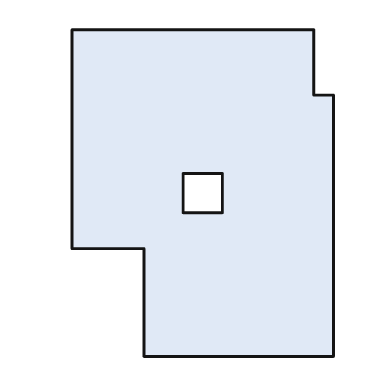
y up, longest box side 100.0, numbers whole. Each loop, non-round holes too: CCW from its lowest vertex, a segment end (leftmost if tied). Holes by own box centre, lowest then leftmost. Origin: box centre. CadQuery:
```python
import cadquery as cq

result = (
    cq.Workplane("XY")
    .moveTo(-18.0, -50.0)
    .lineTo(40.0, -50.0)
    .lineTo(40.0, 30.0)
    .lineTo(34.0, 30.0)
    .lineTo(34.0, 50.0)
    .lineTo(-40.0, 50.0)
    .lineTo(-40.0, -17.0)
    .lineTo(-18.0, -17.0)
    .close()
    .moveTo(-6.0, -6.0)
    .lineTo(6.0, -6.0)
    .lineTo(6.0, 6.0)
    .lineTo(-6.0, 6.0)
    .close()
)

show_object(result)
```